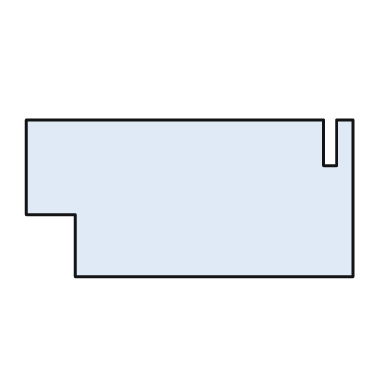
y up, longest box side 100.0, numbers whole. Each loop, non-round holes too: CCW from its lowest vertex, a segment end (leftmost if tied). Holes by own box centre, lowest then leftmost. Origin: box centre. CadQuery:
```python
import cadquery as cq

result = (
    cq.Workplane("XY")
    .moveTo(-35.0, -24.0)
    .lineTo(50.0, -24.0)
    .lineTo(50.0, 24.0)
    .lineTo(45.0, 24.0)
    .lineTo(45.0, 10.0)
    .lineTo(41.0, 10.0)
    .lineTo(41.0, 24.0)
    .lineTo(-50.0, 24.0)
    .lineTo(-50.0, -5.0)
    .lineTo(-35.0, -5.0)
    .close()
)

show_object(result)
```